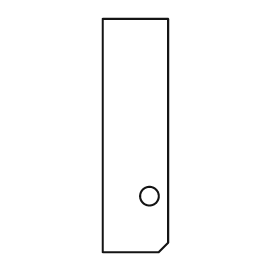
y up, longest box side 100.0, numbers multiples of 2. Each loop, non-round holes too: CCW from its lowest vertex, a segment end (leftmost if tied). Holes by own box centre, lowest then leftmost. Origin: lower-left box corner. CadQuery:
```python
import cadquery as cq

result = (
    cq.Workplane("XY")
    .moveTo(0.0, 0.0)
    .lineTo(24.0, 0.0)
    .lineTo(28.0, 4.0)
    .lineTo(28.0, 100.0)
    .lineTo(0.0, 100.0)
    .close()
    .moveTo(20.0, 24.0)
    .circle(4.0)
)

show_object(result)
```